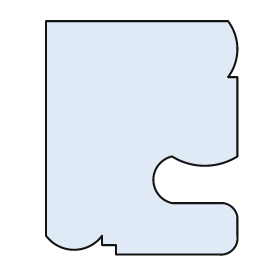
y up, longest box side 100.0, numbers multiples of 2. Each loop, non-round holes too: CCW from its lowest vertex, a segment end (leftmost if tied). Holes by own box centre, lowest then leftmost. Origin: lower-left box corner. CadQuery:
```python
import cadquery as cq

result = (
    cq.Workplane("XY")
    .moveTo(30.0, 0.0)
    .lineTo(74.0, 0.0)
    .threePointArc((80.0, 2.0), (82.0, 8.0))
    .lineTo(82.0, 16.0)
    .threePointArc((80.0, 20.0), (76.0, 22.0))
    .lineTo(54.0, 22.0)
    .threePointArc((46.0, 32.0), (54.0, 42.0))
    .threePointArc((68.0, 38.0), (82.0, 42.0))
    .lineTo(82.0, 76.0)
    .lineTo(78.0, 76.0)
    .threePointArc((82.0, 88.0), (78.0, 100.0))
    .lineTo(0.0, 100.0)
    .lineTo(0.0, 8.0)
    .threePointArc((12.0, 2.0), (24.0, 8.0))
    .lineTo(24.0, 4.0)
    .lineTo(30.0, 4.0)
    .close()
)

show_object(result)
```